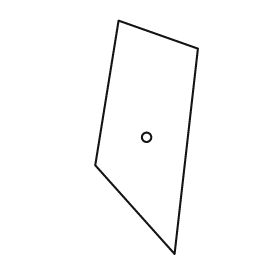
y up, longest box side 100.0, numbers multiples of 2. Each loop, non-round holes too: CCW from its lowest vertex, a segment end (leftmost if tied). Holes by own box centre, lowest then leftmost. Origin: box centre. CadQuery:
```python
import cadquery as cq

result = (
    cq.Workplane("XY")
    .moveTo(12.0, -50.0)
    .lineTo(22.0, 38.0)
    .lineTo(-12.0, 50.0)
    .lineTo(-22.0, -12.0)
    .close()
    .moveTo(0.0, 0.0)
    .circle(2.0)
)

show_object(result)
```